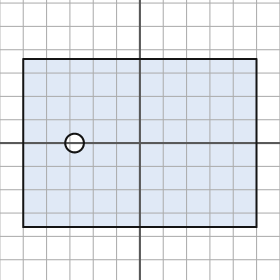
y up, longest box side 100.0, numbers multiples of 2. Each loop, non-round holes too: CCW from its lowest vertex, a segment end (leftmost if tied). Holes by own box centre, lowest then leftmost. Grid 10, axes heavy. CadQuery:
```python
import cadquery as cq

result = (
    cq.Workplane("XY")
    .moveTo(-50.0, -36.0)
    .lineTo(50.0, -36.0)
    .lineTo(50.0, 36.0)
    .lineTo(-50.0, 36.0)
    .close()
    .moveTo(-28.0, 0.0)
    .circle(4.0)
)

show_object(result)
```